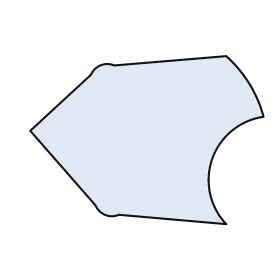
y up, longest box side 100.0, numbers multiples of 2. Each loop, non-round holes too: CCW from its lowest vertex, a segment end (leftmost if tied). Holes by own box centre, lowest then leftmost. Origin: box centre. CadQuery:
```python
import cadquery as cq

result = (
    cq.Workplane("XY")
    .moveTo(34.0, -36.0)
    .threePointArc((28.0, -8.0), (50.0, 10.0))
    .threePointArc((44.0, 24.0), (34.0, 36.0))
    .lineTo(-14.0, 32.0)
    .threePointArc((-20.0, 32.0), (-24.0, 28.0))
    .lineTo(-50.0, 4.0)
    .lineTo(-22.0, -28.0)
    .threePointArc((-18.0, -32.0), (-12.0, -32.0))
    .close()
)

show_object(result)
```